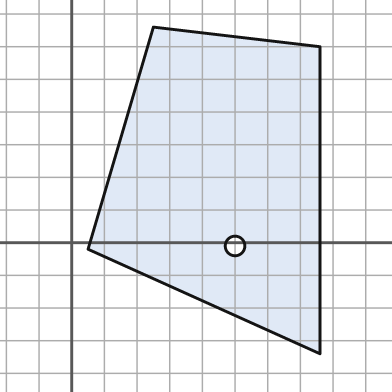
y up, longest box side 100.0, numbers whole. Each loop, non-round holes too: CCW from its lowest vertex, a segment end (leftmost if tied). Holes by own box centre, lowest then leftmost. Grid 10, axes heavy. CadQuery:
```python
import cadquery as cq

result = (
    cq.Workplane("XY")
    .moveTo(76.0, -34.0)
    .lineTo(76.0, 60.0)
    .lineTo(25.0, 66.0)
    .lineTo(5.0, -2.0)
    .close()
    .moveTo(50.0, -1.0)
    .circle(3.0)
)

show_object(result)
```